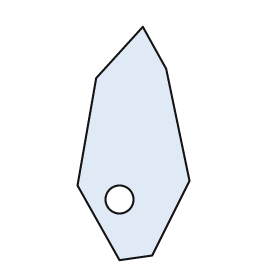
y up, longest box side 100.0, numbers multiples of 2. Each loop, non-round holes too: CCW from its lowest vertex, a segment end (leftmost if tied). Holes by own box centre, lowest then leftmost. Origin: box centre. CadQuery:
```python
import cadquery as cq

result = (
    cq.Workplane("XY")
    .moveTo(-6.0, -50.0)
    .lineTo(8.0, -48.0)
    .lineTo(24.0, -16.0)
    .lineTo(14.0, 32.0)
    .lineTo(4.0, 50.0)
    .lineTo(-16.0, 28.0)
    .lineTo(-24.0, -18.0)
    .close()
    .moveTo(-6.0, -24.0)
    .circle(6.0)
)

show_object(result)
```